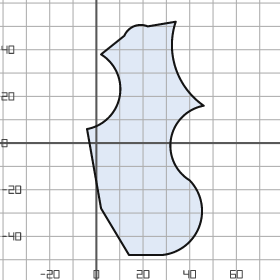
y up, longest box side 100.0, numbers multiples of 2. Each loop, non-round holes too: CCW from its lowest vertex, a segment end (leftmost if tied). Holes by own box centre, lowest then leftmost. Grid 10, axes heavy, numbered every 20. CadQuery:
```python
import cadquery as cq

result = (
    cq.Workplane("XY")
    .moveTo(14.0, -48.0)
    .lineTo(28.0, -48.0)
    .threePointArc((44.0, -36.0), (40.0, -16.0))
    .threePointArc((32.0, 2.0), (46.0, 16.0))
    .threePointArc((34.0, 32.0), (34.0, 52.0))
    .lineTo(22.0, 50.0)
    .threePointArc((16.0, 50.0), (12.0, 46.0))
    .lineTo(2.0, 38.0)
    .threePointArc((10.0, 20.0), (-4.0, 6.0))
    .lineTo(2.0, -28.0)
    .close()
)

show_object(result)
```